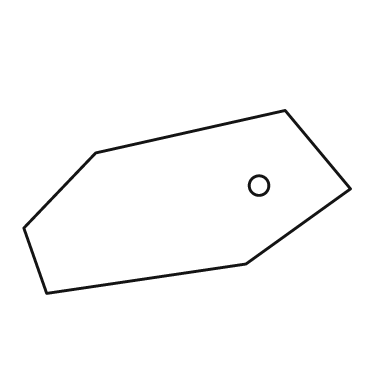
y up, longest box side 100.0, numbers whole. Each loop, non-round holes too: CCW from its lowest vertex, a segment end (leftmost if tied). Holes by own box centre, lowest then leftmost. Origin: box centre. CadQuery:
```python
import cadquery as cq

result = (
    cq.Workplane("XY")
    .moveTo(-43.0, -28.0)
    .lineTo(18.0, -19.0)
    .lineTo(50.0, 4.0)
    .lineTo(30.0, 28.0)
    .lineTo(-28.0, 15.0)
    .lineTo(-50.0, -8.0)
    .close()
    .moveTo(22.0, 5.0)
    .circle(3.0)
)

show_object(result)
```